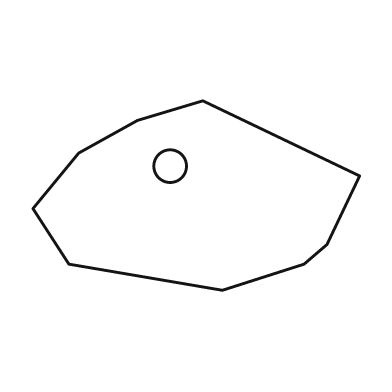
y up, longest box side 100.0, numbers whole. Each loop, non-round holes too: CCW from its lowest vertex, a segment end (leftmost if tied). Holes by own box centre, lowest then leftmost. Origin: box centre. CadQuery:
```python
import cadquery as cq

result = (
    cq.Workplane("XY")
    .moveTo(8.0, -29.0)
    .lineTo(33.0, -21.0)
    .lineTo(40.0, -15.0)
    .lineTo(50.0, 6.0)
    .lineTo(2.0, 29.0)
    .lineTo(-18.0, 23.0)
    .lineTo(-36.0, 13.0)
    .lineTo(-50.0, -4.0)
    .lineTo(-39.0, -21.0)
    .close()
    .moveTo(-8.0, 9.0)
    .circle(5.0)
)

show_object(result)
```